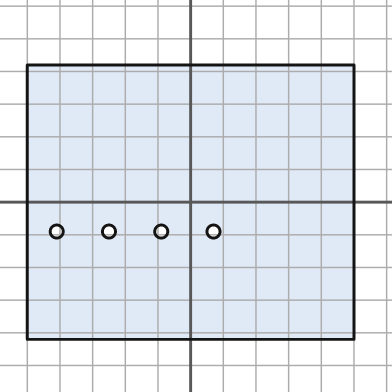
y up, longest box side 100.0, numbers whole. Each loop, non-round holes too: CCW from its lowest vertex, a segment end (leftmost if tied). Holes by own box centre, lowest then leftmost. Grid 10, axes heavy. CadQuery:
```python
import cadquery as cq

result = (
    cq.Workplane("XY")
    .moveTo(-50.0, -42.0)
    .lineTo(50.0, -42.0)
    .lineTo(50.0, 42.0)
    .lineTo(-50.0, 42.0)
    .close()
    .moveTo(-41.0, -9.0)
    .circle(2.0)
    .moveTo(-25.0, -9.0)
    .circle(2.0)
    .moveTo(-9.0, -9.0)
    .circle(2.0)
    .moveTo(7.0, -9.0)
    .circle(2.0)
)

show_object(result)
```